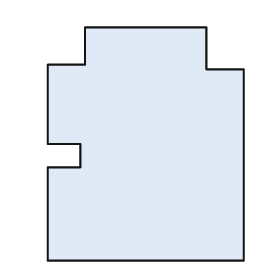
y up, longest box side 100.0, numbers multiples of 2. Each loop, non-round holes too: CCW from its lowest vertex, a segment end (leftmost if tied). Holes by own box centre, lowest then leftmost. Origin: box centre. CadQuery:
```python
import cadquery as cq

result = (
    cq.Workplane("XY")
    .moveTo(-42.0, -50.0)
    .lineTo(42.0, -50.0)
    .lineTo(42.0, 32.0)
    .lineTo(26.0, 32.0)
    .lineTo(26.0, 50.0)
    .lineTo(-26.0, 50.0)
    .lineTo(-26.0, 34.0)
    .lineTo(-42.0, 34.0)
    .lineTo(-42.0, 0.0)
    .lineTo(-28.0, 0.0)
    .lineTo(-28.0, -10.0)
    .lineTo(-42.0, -10.0)
    .close()
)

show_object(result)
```